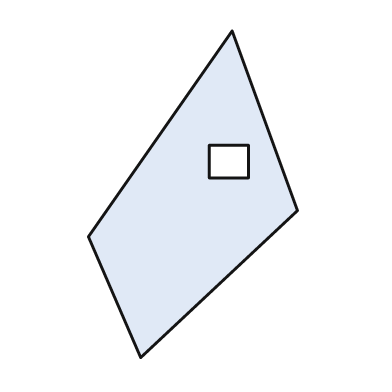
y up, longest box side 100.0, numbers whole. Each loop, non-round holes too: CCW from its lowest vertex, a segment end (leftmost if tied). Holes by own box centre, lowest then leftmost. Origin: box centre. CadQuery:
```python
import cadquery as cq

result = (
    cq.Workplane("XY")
    .moveTo(-16.0, -50.0)
    .lineTo(32.0, -5.0)
    .lineTo(12.0, 50.0)
    .lineTo(-32.0, -13.0)
    .close()
    .moveTo(5.0, 5.0)
    .lineTo(17.0, 5.0)
    .lineTo(17.0, 15.0)
    .lineTo(5.0, 15.0)
    .close()
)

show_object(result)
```